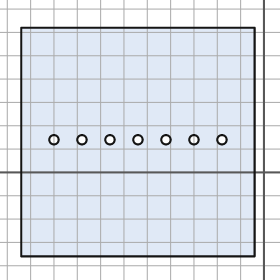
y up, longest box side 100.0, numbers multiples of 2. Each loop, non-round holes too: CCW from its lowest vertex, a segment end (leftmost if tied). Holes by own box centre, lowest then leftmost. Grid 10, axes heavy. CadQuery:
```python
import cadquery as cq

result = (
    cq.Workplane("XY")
    .moveTo(-104.0, -36.0)
    .lineTo(-4.0, -36.0)
    .lineTo(-4.0, 62.0)
    .lineTo(-104.0, 62.0)
    .close()
    .moveTo(-90.0, 14.0)
    .circle(2.0)
    .moveTo(-78.0, 14.0)
    .circle(2.0)
    .moveTo(-66.0, 14.0)
    .circle(2.0)
    .moveTo(-54.0, 14.0)
    .circle(2.0)
    .moveTo(-42.0, 14.0)
    .circle(2.0)
    .moveTo(-30.0, 14.0)
    .circle(2.0)
    .moveTo(-18.0, 14.0)
    .circle(2.0)
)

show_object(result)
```